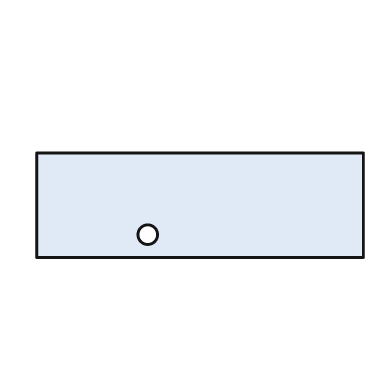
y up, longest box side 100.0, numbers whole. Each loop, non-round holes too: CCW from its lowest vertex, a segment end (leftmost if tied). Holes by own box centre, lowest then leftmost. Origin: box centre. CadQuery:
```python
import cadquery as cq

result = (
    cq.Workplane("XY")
    .moveTo(-50.0, -16.0)
    .lineTo(50.0, -16.0)
    .lineTo(50.0, 16.0)
    .lineTo(-50.0, 16.0)
    .close()
    .moveTo(-16.0, -9.0)
    .circle(3.0)
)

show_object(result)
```